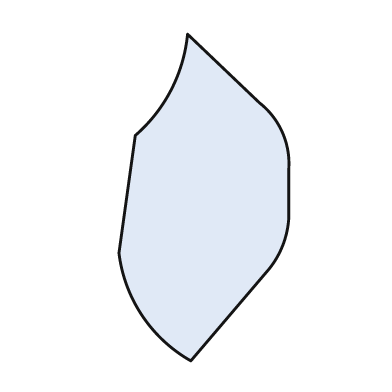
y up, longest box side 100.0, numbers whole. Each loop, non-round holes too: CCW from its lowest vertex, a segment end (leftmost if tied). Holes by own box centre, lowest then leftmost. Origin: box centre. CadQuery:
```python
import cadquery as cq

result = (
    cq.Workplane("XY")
    .moveTo(-4.0, -50.0)
    .lineTo(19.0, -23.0)
    .threePointArc((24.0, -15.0), (26.0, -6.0))
    .lineTo(26.0, 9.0)
    .threePointArc((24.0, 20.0), (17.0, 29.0))
    .lineTo(-5.0, 50.0)
    .threePointArc((-10.0, 33.0), (-21.0, 19.0))
    .lineTo(-26.0, -17.0)
    .threePointArc((-19.0, -36.0), (-4.0, -50.0))
    .close()
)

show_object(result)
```